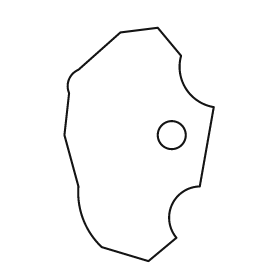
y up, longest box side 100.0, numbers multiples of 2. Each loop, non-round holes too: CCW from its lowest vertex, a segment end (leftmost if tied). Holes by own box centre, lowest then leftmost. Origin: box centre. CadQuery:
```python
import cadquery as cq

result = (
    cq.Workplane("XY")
    .moveTo(4.0, -50.0)
    .lineTo(16.0, -40.0)
    .threePointArc((14.0, -26.0), (26.0, -18.0))
    .lineTo(32.0, 16.0)
    .threePointArc((20.0, 24.0), (18.0, 38.0))
    .lineTo(8.0, 50.0)
    .lineTo(-8.0, 48.0)
    .lineTo(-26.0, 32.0)
    .threePointArc((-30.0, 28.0), (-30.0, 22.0))
    .lineTo(-32.0, 4.0)
    .lineTo(-26.0, -18.0)
    .threePointArc((-24.0, -32.0), (-16.0, -44.0))
    .close()
    .moveTo(14.0, 4.0)
    .circle(6.0)
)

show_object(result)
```